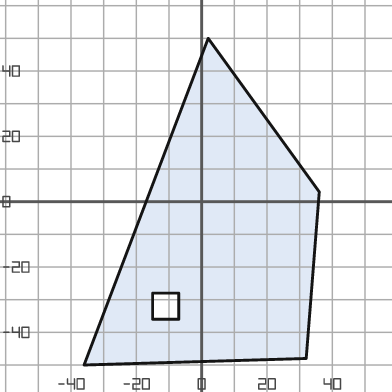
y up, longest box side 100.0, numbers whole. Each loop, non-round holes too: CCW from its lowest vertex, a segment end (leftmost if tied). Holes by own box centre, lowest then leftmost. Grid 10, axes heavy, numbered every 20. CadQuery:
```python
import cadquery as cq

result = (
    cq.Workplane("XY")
    .moveTo(-36.0, -50.0)
    .lineTo(32.0, -48.0)
    .lineTo(36.0, 3.0)
    .lineTo(2.0, 50.0)
    .close()
    .moveTo(-15.0, -36.0)
    .lineTo(-7.0, -36.0)
    .lineTo(-7.0, -28.0)
    .lineTo(-15.0, -28.0)
    .close()
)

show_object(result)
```